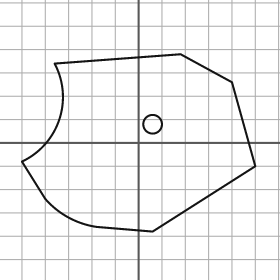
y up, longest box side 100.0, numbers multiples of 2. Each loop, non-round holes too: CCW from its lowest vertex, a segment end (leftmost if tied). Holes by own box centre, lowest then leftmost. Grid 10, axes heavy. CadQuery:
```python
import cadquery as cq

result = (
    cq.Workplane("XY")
    .moveTo(6.0, -38.0)
    .lineTo(50.0, -10.0)
    .lineTo(40.0, 26.0)
    .lineTo(18.0, 38.0)
    .lineTo(-36.0, 34.0)
    .threePointArc((-34.0, 10.0), (-50.0, -8.0))
    .lineTo(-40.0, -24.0)
    .threePointArc((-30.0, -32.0), (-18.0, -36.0))
    .close()
    .moveTo(6.0, 8.0)
    .circle(4.0)
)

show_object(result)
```